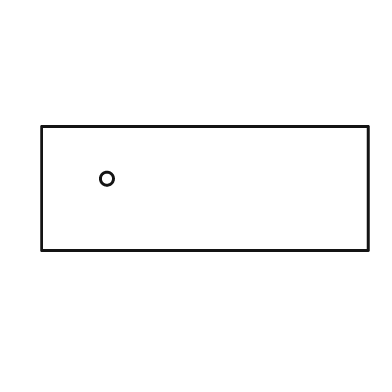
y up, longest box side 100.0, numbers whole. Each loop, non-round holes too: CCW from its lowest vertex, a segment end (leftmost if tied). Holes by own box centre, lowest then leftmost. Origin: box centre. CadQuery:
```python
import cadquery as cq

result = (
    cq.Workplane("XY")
    .moveTo(-50.0, -19.0)
    .lineTo(50.0, -19.0)
    .lineTo(50.0, 19.0)
    .lineTo(-50.0, 19.0)
    .close()
    .moveTo(-30.0, 3.0)
    .circle(2.0)
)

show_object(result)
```